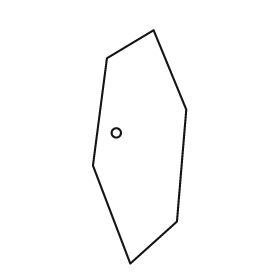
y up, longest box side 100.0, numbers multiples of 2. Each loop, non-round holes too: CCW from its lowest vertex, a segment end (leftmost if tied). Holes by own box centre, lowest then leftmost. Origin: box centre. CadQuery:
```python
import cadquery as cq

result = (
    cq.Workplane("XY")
    .moveTo(-4.0, -50.0)
    .lineTo(16.0, -32.0)
    .lineTo(20.0, 16.0)
    .lineTo(6.0, 50.0)
    .lineTo(-14.0, 38.0)
    .lineTo(-20.0, -8.0)
    .close()
    .moveTo(-10.0, 6.0)
    .circle(2.0)
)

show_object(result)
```